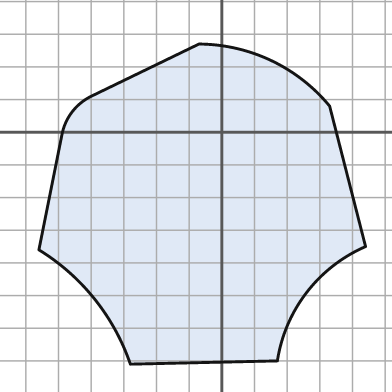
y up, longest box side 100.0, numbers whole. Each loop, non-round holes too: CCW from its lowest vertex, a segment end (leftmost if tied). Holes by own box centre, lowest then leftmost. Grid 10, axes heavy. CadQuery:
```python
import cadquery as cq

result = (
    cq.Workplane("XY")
    .moveTo(-28.0, -71.0)
    .lineTo(17.0, -70.0)
    .threePointArc((26.0, -49.0), (44.0, -35.0))
    .lineTo(33.0, 8.0)
    .threePointArc((15.0, 22.0), (-7.0, 27.0))
    .lineTo(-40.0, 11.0)
    .threePointArc((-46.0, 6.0), (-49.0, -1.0))
    .lineTo(-56.0, -36.0)
    .threePointArc((-39.0, -51.0), (-28.0, -71.0))
    .close()
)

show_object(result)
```